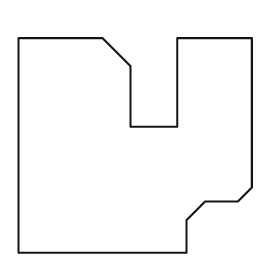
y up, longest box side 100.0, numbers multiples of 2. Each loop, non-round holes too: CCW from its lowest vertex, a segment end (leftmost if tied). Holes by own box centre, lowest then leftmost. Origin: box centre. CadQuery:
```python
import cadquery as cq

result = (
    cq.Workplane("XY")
    .moveTo(-50.0, -46.0)
    .lineTo(22.0, -46.0)
    .lineTo(22.0, -32.0)
    .lineTo(30.0, -24.0)
    .lineTo(44.0, -24.0)
    .lineTo(50.0, -18.0)
    .lineTo(50.0, 46.0)
    .lineTo(18.0, 46.0)
    .lineTo(18.0, 8.0)
    .lineTo(-2.0, 8.0)
    .lineTo(-2.0, 34.0)
    .lineTo(-14.0, 46.0)
    .lineTo(-50.0, 46.0)
    .close()
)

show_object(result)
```